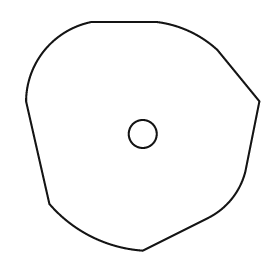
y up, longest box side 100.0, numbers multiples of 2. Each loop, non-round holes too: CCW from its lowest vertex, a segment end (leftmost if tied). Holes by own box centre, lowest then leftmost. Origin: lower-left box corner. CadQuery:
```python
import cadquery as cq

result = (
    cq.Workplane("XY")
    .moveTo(50.0, 0.0)
    .lineTo(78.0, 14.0)
    .threePointArc((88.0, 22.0), (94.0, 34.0))
    .lineTo(100.0, 64.0)
    .lineTo(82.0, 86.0)
    .threePointArc((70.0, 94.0), (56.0, 98.0))
    .lineTo(28.0, 98.0)
    .threePointArc((8.0, 86.0), (0.0, 64.0))
    .lineTo(10.0, 20.0)
    .threePointArc((28.0, 6.0), (50.0, 0.0))
    .close()
    .moveTo(50.0, 50.0)
    .circle(6.0)
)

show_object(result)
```